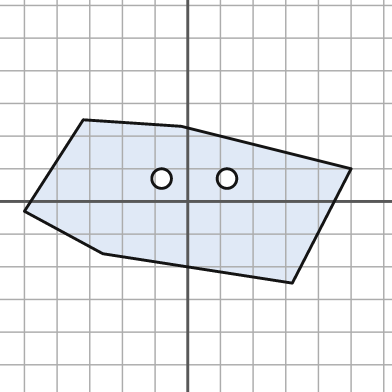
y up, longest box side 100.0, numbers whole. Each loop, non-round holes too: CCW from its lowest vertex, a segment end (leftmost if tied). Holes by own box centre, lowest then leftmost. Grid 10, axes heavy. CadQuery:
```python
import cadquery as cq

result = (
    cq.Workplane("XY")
    .moveTo(32.0, -25.0)
    .lineTo(50.0, 10.0)
    .lineTo(-2.0, 23.0)
    .lineTo(-32.0, 25.0)
    .lineTo(-50.0, -3.0)
    .lineTo(-26.0, -16.0)
    .close()
    .moveTo(-8.0, 7.0)
    .circle(3.0)
    .moveTo(12.0, 7.0)
    .circle(3.0)
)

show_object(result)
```